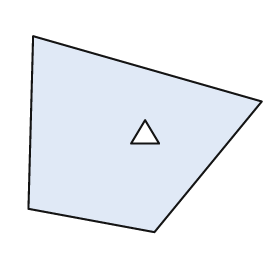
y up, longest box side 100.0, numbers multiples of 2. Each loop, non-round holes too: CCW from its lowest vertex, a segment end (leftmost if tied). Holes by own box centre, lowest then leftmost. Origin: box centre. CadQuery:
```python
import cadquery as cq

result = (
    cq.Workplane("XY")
    .moveTo(4.0, -42.0)
    .lineTo(50.0, 14.0)
    .lineTo(-48.0, 42.0)
    .lineTo(-50.0, -32.0)
    .close()
    .moveTo(-6.0, -4.0)
    .lineTo(6.0, -4.0)
    .lineTo(0.0, 6.0)
    .close()
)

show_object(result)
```